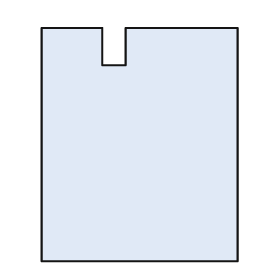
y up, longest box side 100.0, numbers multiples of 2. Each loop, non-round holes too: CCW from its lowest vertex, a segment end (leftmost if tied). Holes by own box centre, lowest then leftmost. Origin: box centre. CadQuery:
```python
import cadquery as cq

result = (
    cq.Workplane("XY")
    .moveTo(-42.0, -50.0)
    .lineTo(42.0, -50.0)
    .lineTo(42.0, 50.0)
    .lineTo(-6.0, 50.0)
    .lineTo(-6.0, 34.0)
    .lineTo(-16.0, 34.0)
    .lineTo(-16.0, 50.0)
    .lineTo(-42.0, 50.0)
    .close()
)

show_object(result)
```